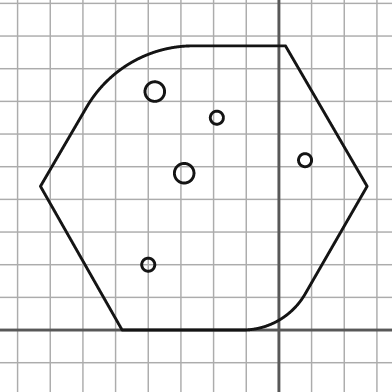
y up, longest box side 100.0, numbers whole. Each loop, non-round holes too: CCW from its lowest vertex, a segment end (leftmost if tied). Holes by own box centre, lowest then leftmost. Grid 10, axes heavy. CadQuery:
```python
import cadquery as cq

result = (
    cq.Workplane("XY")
    .moveTo(-48.0, 0.0)
    .lineTo(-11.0, 0.0)
    .threePointArc((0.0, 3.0), (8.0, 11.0))
    .lineTo(27.0, 44.0)
    .lineTo(2.0, 87.0)
    .lineTo(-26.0, 87.0)
    .threePointArc((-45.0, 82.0), (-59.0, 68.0))
    .lineTo(-73.0, 44.0)
    .close()
    .moveTo(-40.0, 20.0)
    .circle(2.0)
    .moveTo(-29.0, 48.0)
    .circle(3.0)
    .moveTo(8.0, 52.0)
    .circle(2.0)
    .moveTo(-19.0, 65.0)
    .circle(2.0)
    .moveTo(-38.0, 73.0)
    .circle(3.0)
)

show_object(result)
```